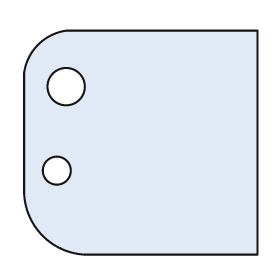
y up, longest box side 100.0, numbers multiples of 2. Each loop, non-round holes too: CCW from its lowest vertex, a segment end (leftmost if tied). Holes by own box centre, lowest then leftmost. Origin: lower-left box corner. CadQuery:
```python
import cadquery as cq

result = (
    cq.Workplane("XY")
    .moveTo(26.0, 0.0)
    .lineTo(100.0, 0.0)
    .lineTo(100.0, 96.0)
    .lineTo(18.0, 96.0)
    .threePointArc((6.0, 90.0), (0.0, 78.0))
    .lineTo(0.0, 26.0)
    .threePointArc((8.0, 8.0), (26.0, 0.0))
    .close()
    .moveTo(14.0, 36.0)
    .circle(6.0)
    .moveTo(18.0, 72.0)
    .circle(8.0)
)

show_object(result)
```